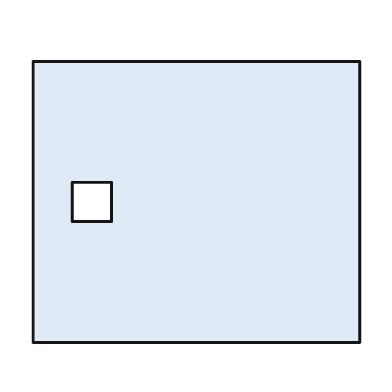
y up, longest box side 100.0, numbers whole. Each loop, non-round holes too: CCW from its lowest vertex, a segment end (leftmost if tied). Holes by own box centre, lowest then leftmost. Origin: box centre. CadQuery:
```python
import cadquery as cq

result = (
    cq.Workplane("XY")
    .moveTo(-50.0, -43.0)
    .lineTo(50.0, -43.0)
    .lineTo(50.0, 43.0)
    .lineTo(-50.0, 43.0)
    .close()
    .moveTo(-38.0, -6.0)
    .lineTo(-26.0, -6.0)
    .lineTo(-26.0, 6.0)
    .lineTo(-38.0, 6.0)
    .close()
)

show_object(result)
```